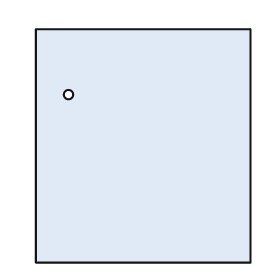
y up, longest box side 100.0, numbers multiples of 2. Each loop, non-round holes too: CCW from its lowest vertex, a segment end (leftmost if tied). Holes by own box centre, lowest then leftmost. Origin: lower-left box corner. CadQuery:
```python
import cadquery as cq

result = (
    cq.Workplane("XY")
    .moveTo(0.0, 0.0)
    .lineTo(92.0, 0.0)
    .lineTo(92.0, 100.0)
    .lineTo(0.0, 100.0)
    .close()
    .moveTo(14.0, 72.0)
    .circle(2.0)
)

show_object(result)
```